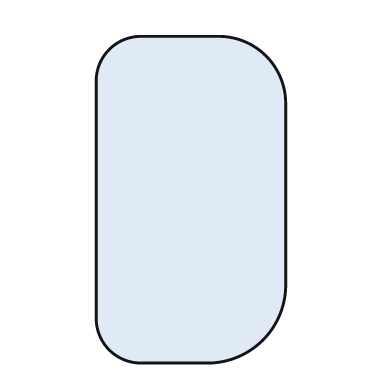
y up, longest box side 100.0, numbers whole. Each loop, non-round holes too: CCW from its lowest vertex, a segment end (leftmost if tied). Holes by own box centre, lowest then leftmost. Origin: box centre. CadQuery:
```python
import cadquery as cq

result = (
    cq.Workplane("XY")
    .moveTo(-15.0, -50.0)
    .lineTo(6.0, -50.0)
    .threePointArc((22.0, -43.0), (29.0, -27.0))
    .lineTo(29.0, 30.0)
    .threePointArc((23.0, 44.0), (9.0, 50.0))
    .lineTo(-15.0, 50.0)
    .threePointArc((-25.0, 46.0), (-29.0, 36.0))
    .lineTo(-29.0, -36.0)
    .threePointArc((-25.0, -46.0), (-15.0, -50.0))
    .close()
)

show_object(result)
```